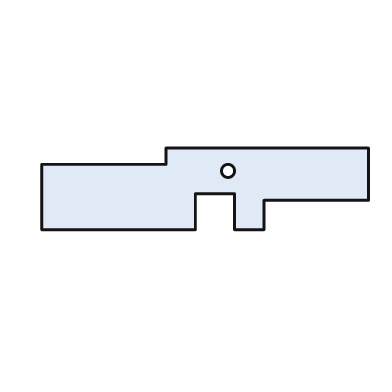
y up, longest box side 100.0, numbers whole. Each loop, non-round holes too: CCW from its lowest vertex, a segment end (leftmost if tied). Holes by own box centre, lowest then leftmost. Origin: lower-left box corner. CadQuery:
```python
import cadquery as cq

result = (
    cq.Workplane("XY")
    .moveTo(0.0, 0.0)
    .lineTo(47.0, 0.0)
    .lineTo(47.0, 11.0)
    .lineTo(59.0, 11.0)
    .lineTo(59.0, 0.0)
    .lineTo(68.0, 0.0)
    .lineTo(68.0, 9.0)
    .lineTo(100.0, 9.0)
    .lineTo(100.0, 25.0)
    .lineTo(38.0, 25.0)
    .lineTo(38.0, 20.0)
    .lineTo(0.0, 20.0)
    .close()
    .moveTo(57.0, 18.0)
    .circle(2.0)
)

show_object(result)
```